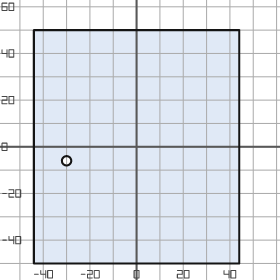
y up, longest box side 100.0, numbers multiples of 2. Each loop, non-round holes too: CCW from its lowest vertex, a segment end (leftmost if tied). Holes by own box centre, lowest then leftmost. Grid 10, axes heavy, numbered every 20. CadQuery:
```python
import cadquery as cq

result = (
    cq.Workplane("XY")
    .moveTo(-44.0, -50.0)
    .lineTo(44.0, -50.0)
    .lineTo(44.0, 50.0)
    .lineTo(-44.0, 50.0)
    .close()
    .moveTo(-30.0, -6.0)
    .circle(2.0)
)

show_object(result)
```